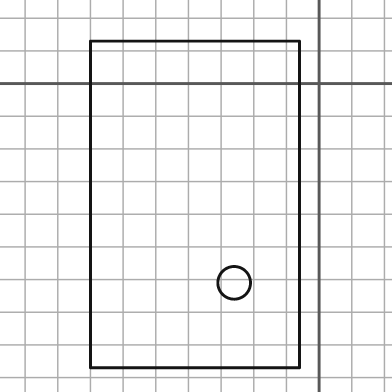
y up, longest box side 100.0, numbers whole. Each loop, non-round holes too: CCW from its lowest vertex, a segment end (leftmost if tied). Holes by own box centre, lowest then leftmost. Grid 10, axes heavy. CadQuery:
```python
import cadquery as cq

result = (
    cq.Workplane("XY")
    .moveTo(-70.0, -87.0)
    .lineTo(-6.0, -87.0)
    .lineTo(-6.0, 13.0)
    .lineTo(-70.0, 13.0)
    .close()
    .moveTo(-26.0, -61.0)
    .circle(5.0)
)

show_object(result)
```